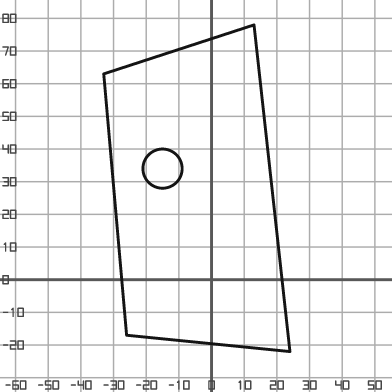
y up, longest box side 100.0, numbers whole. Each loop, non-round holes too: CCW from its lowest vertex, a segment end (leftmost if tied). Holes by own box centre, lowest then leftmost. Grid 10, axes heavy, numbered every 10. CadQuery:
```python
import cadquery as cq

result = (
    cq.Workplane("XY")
    .moveTo(24.0, -22.0)
    .lineTo(13.0, 78.0)
    .lineTo(-33.0, 63.0)
    .lineTo(-26.0, -17.0)
    .close()
    .moveTo(-15.0, 34.0)
    .circle(6.0)
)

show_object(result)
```